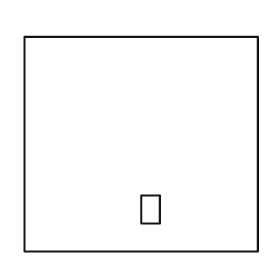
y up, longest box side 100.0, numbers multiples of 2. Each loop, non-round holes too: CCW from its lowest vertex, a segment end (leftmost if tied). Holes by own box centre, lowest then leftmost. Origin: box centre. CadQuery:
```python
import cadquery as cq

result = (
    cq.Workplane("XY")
    .moveTo(-50.0, -46.0)
    .lineTo(50.0, -46.0)
    .lineTo(50.0, 46.0)
    .lineTo(-50.0, 46.0)
    .close()
    .moveTo(0.0, -34.0)
    .lineTo(8.0, -34.0)
    .lineTo(8.0, -22.0)
    .lineTo(0.0, -22.0)
    .close()
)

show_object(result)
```